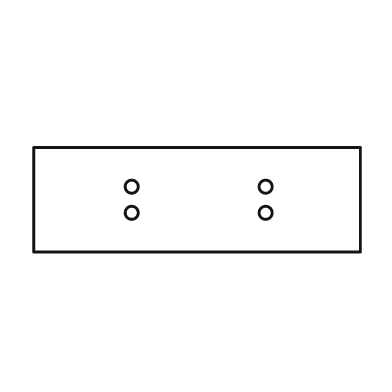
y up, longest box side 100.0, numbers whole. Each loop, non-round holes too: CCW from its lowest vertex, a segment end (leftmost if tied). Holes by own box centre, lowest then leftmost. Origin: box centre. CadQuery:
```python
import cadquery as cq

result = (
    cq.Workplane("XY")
    .moveTo(-50.0, -16.0)
    .lineTo(50.0, -16.0)
    .lineTo(50.0, 16.0)
    .lineTo(-50.0, 16.0)
    .close()
    .moveTo(-20.0, -4.0)
    .circle(2.0)
    .moveTo(21.0, -4.0)
    .circle(2.0)
    .moveTo(-20.0, 4.0)
    .circle(2.0)
    .moveTo(21.0, 4.0)
    .circle(2.0)
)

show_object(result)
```